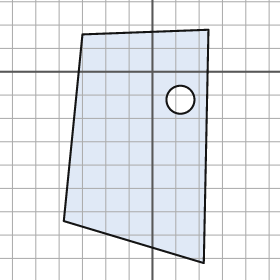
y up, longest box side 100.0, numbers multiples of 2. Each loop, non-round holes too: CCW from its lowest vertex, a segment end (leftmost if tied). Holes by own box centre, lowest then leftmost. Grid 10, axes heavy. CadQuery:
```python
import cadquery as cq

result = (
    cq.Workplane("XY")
    .moveTo(22.0, -82.0)
    .lineTo(24.0, 18.0)
    .lineTo(-30.0, 16.0)
    .lineTo(-38.0, -64.0)
    .close()
    .moveTo(12.0, -12.0)
    .circle(6.0)
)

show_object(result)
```